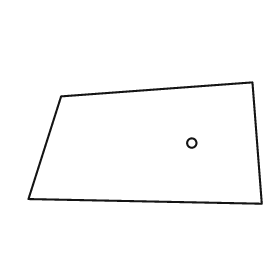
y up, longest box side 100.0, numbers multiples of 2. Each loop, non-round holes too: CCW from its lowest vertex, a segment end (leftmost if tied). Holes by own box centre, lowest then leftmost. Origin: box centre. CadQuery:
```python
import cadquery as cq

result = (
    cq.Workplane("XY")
    .moveTo(50.0, -26.0)
    .lineTo(46.0, 26.0)
    .lineTo(-36.0, 20.0)
    .lineTo(-50.0, -24.0)
    .close()
    .moveTo(20.0, 0.0)
    .circle(2.0)
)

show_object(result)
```